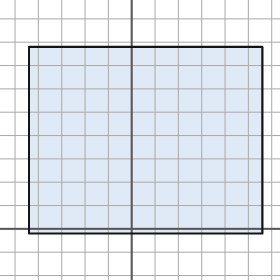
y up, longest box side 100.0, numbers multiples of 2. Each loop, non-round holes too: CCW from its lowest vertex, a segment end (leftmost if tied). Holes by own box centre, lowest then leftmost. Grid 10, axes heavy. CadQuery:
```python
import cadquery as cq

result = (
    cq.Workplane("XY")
    .moveTo(-44.0, -2.0)
    .lineTo(56.0, -2.0)
    .lineTo(56.0, 78.0)
    .lineTo(-44.0, 78.0)
    .close()
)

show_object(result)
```